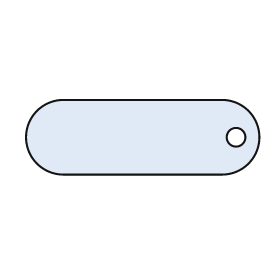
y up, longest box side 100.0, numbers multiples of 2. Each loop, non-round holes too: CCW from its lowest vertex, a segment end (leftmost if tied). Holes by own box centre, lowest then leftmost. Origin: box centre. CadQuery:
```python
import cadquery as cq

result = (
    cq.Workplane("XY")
    .moveTo(-34.0, -16.0)
    .lineTo(34.0, -16.0)
    .threePointArc((50.0, 0.0), (34.0, 16.0))
    .lineTo(-34.0, 16.0)
    .threePointArc((-50.0, 0.0), (-34.0, -16.0))
    .close()
    .moveTo(40.0, 0.0)
    .circle(4.0)
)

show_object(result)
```